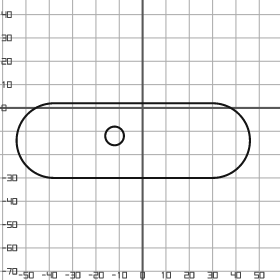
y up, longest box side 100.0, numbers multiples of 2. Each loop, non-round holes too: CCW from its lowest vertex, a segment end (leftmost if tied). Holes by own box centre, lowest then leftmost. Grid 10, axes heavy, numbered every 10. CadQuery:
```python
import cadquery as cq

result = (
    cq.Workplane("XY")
    .moveTo(-38.0, -30.0)
    .lineTo(30.0, -30.0)
    .threePointArc((46.0, -14.0), (30.0, 2.0))
    .lineTo(-38.0, 2.0)
    .threePointArc((-54.0, -14.0), (-38.0, -30.0))
    .close()
    .moveTo(-12.0, -12.0)
    .circle(4.0)
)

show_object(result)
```